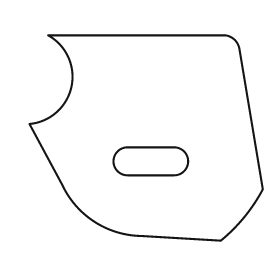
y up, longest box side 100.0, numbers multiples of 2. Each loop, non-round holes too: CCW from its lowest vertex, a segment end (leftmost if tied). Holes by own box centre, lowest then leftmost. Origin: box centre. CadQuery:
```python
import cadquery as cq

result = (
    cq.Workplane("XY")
    .moveTo(32.0, -44.0)
    .threePointArc((42.0, -34.0), (50.0, -22.0))
    .lineTo(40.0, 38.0)
    .threePointArc((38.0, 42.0), (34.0, 44.0))
    .lineTo(-42.0, 44.0)
    .threePointArc((-32.0, 22.0), (-50.0, 6.0))
    .lineTo(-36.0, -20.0)
    .threePointArc((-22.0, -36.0), (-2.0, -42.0))
    .close()
    .moveTo(-8.0, -16.0)
    .lineTo(12.0, -16.0)
    .threePointArc((18.0, -10.0), (12.0, -4.0))
    .lineTo(-8.0, -4.0)
    .threePointArc((-14.0, -10.0), (-8.0, -16.0))
    .close()
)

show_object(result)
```